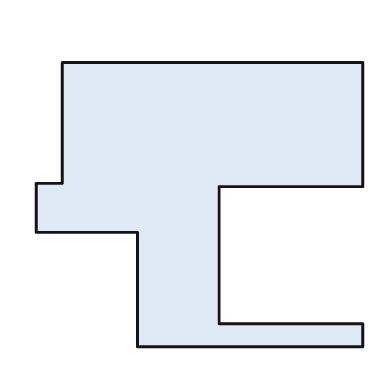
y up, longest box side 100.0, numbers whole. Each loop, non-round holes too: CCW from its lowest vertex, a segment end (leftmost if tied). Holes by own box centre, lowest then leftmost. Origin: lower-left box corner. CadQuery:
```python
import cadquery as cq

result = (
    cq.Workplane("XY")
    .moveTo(31.0, 0.0)
    .lineTo(100.0, 0.0)
    .lineTo(100.0, 7.0)
    .lineTo(56.0, 7.0)
    .lineTo(56.0, 49.0)
    .lineTo(100.0, 49.0)
    .lineTo(100.0, 87.0)
    .lineTo(8.0, 87.0)
    .lineTo(8.0, 50.0)
    .lineTo(0.0, 50.0)
    .lineTo(0.0, 35.0)
    .lineTo(31.0, 35.0)
    .close()
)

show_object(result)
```